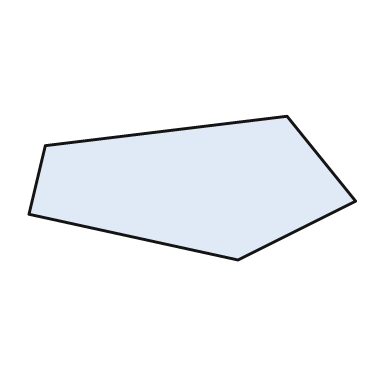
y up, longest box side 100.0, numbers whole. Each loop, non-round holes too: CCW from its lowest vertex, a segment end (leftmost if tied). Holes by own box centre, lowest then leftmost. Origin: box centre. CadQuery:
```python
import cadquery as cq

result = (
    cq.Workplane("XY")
    .moveTo(14.0, -22.0)
    .lineTo(50.0, -4.0)
    .lineTo(29.0, 22.0)
    .lineTo(-45.0, 13.0)
    .lineTo(-50.0, -8.0)
    .close()
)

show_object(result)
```